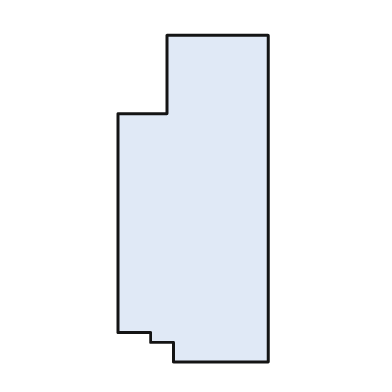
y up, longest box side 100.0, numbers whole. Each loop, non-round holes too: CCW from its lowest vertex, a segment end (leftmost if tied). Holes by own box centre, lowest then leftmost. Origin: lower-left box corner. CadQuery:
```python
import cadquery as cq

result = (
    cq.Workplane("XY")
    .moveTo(17.0, 0.0)
    .lineTo(46.0, 0.0)
    .lineTo(46.0, 100.0)
    .lineTo(15.0, 100.0)
    .lineTo(15.0, 76.0)
    .lineTo(0.0, 76.0)
    .lineTo(0.0, 9.0)
    .lineTo(10.0, 9.0)
    .lineTo(10.0, 6.0)
    .lineTo(17.0, 6.0)
    .close()
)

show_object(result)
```